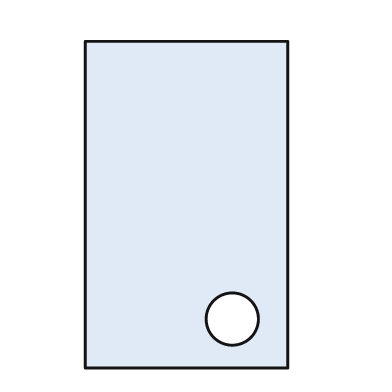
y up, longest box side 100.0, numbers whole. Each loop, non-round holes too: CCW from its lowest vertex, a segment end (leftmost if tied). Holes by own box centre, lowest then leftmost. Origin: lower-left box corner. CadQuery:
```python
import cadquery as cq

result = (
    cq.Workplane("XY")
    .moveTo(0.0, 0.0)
    .lineTo(62.0, 0.0)
    .lineTo(62.0, 100.0)
    .lineTo(0.0, 100.0)
    .close()
    .moveTo(45.0, 15.0)
    .circle(8.0)
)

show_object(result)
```